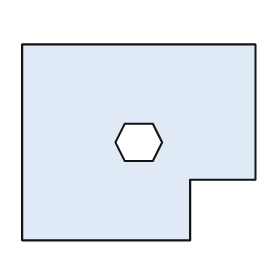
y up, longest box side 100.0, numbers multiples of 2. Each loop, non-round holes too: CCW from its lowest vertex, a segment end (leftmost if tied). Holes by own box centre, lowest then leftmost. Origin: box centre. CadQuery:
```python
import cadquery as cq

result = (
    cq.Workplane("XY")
    .moveTo(-50.0, -42.0)
    .lineTo(22.0, -42.0)
    .lineTo(22.0, -16.0)
    .lineTo(50.0, -16.0)
    .lineTo(50.0, 42.0)
    .lineTo(-50.0, 42.0)
    .close()
    .moveTo(-6.0, -8.0)
    .lineTo(6.0, -8.0)
    .lineTo(10.0, 0.0)
    .lineTo(6.0, 8.0)
    .lineTo(-6.0, 8.0)
    .lineTo(-10.0, 0.0)
    .close()
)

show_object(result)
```